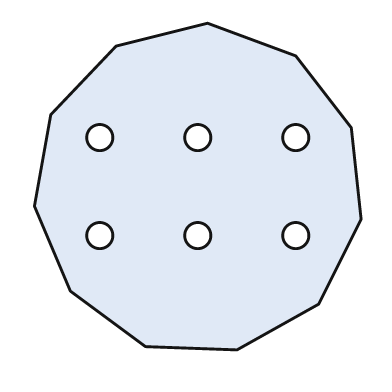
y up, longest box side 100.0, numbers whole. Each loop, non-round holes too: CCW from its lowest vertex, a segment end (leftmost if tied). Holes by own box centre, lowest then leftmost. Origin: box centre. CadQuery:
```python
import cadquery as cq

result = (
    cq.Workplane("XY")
    .moveTo(12.0, -50.0)
    .lineTo(37.0, -36.0)
    .lineTo(50.0, -10.0)
    .lineTo(47.0, 18.0)
    .lineTo(30.0, 40.0)
    .lineTo(3.0, 50.0)
    .lineTo(-25.0, 43.0)
    .lineTo(-45.0, 22.0)
    .lineTo(-50.0, -6.0)
    .lineTo(-39.0, -32.0)
    .lineTo(-16.0, -49.0)
    .close()
    .moveTo(-30.0, -15.0)
    .circle(4.0)
    .moveTo(0.0, -15.0)
    .circle(4.0)
    .moveTo(30.0, -15.0)
    .circle(4.0)
    .moveTo(-30.0, 15.0)
    .circle(4.0)
    .moveTo(0.0, 15.0)
    .circle(4.0)
    .moveTo(30.0, 15.0)
    .circle(4.0)
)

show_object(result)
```